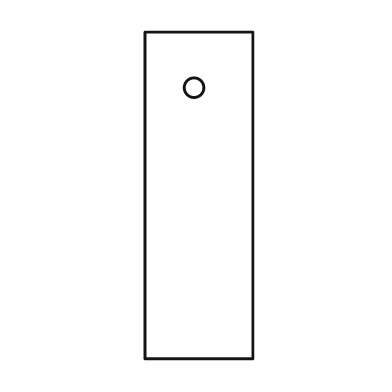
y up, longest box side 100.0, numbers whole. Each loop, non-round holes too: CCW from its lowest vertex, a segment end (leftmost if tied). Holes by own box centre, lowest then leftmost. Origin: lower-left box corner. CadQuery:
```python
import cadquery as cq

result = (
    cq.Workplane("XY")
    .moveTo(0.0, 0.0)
    .lineTo(33.0, 0.0)
    .lineTo(33.0, 100.0)
    .lineTo(0.0, 100.0)
    .close()
    .moveTo(15.0, 83.0)
    .circle(3.0)
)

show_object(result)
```